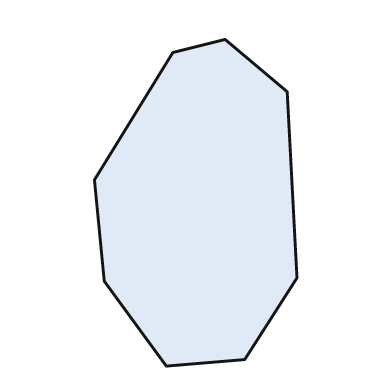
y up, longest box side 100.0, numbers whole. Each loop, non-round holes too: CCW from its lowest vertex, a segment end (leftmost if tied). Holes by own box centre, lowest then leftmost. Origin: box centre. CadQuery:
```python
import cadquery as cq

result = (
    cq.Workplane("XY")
    .moveTo(-9.0, -50.0)
    .lineTo(15.0, -48.0)
    .lineTo(31.0, -23.0)
    .lineTo(28.0, 34.0)
    .lineTo(9.0, 50.0)
    .lineTo(-7.0, 46.0)
    .lineTo(-31.0, 7.0)
    .lineTo(-28.0, -24.0)
    .close()
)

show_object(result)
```